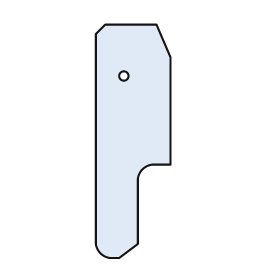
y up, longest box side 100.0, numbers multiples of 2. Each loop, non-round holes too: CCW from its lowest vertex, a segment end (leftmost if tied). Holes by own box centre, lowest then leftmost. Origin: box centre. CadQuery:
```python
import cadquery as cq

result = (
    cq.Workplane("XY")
    .moveTo(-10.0, -50.0)
    .lineTo(-6.0, -50.0)
    .lineTo(2.0, -44.0)
    .lineTo(2.0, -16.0)
    .threePointArc((4.0, -12.0), (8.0, -10.0))
    .lineTo(16.0, -10.0)
    .lineTo(16.0, 36.0)
    .lineTo(10.0, 50.0)
    .lineTo(-12.0, 50.0)
    .lineTo(-16.0, 46.0)
    .lineTo(-16.0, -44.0)
    .threePointArc((-14.0, -48.0), (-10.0, -50.0))
    .close()
    .moveTo(-4.0, 28.0)
    .circle(2.0)
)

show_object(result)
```